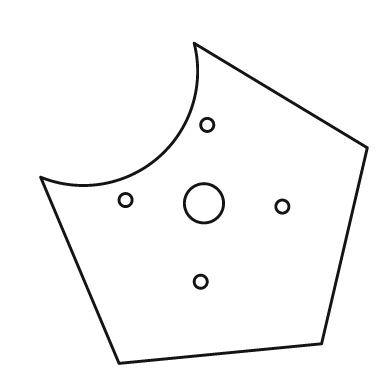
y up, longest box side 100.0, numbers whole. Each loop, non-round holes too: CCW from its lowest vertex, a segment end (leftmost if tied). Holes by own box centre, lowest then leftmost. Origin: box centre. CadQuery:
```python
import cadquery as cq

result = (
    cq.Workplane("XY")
    .moveTo(-26.0, -49.0)
    .lineTo(36.0, -43.0)
    .lineTo(50.0, 17.0)
    .lineTo(-3.0, 49.0)
    .threePointArc((-14.0, 14.0), (-50.0, 8.0))
    .close()
    .moveTo(-1.0, -24.0)
    .circle(2.0)
    .moveTo(24.0, -1.0)
    .circle(2.0)
    .moveTo(0.0, 0.0)
    .circle(6.0)
    .moveTo(-24.0, 1.0)
    .circle(2.0)
    .moveTo(1.0, 24.0)
    .circle(2.0)
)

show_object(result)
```